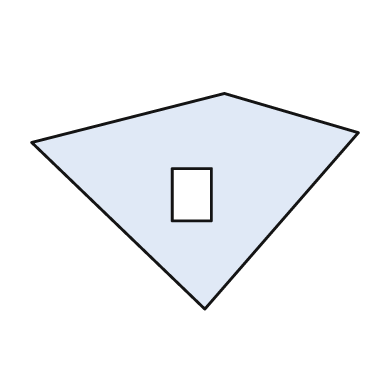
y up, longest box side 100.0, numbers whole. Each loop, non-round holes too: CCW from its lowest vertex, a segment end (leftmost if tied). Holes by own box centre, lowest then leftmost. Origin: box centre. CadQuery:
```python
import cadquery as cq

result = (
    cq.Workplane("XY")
    .moveTo(3.0, -33.0)
    .lineTo(50.0, 21.0)
    .lineTo(9.0, 33.0)
    .lineTo(-50.0, 18.0)
    .close()
    .moveTo(-7.0, -6.0)
    .lineTo(5.0, -6.0)
    .lineTo(5.0, 10.0)
    .lineTo(-7.0, 10.0)
    .close()
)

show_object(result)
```